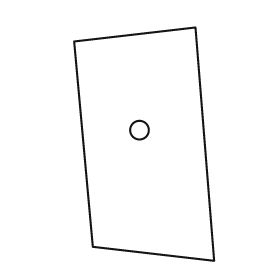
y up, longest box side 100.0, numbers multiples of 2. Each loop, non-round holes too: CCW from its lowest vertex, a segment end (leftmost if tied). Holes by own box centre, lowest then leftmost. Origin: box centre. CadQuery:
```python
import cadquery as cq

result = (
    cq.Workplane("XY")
    .moveTo(30.0, -50.0)
    .lineTo(22.0, 50.0)
    .lineTo(-30.0, 44.0)
    .lineTo(-22.0, -44.0)
    .close()
    .moveTo(-2.0, 6.0)
    .circle(4.0)
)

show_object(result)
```